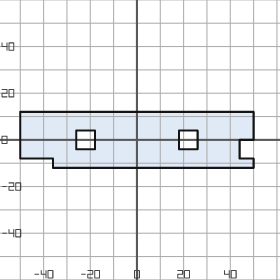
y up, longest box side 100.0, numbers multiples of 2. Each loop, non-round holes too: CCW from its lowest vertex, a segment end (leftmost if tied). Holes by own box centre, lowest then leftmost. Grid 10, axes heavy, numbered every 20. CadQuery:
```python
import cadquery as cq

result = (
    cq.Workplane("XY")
    .moveTo(-36.0, -12.0)
    .lineTo(50.0, -12.0)
    .lineTo(50.0, -8.0)
    .lineTo(44.0, -8.0)
    .lineTo(44.0, 0.0)
    .lineTo(50.0, 0.0)
    .lineTo(50.0, 12.0)
    .lineTo(-50.0, 12.0)
    .lineTo(-50.0, -8.0)
    .lineTo(-36.0, -8.0)
    .close()
    .moveTo(-26.0, -4.0)
    .lineTo(-18.0, -4.0)
    .lineTo(-18.0, 4.0)
    .lineTo(-26.0, 4.0)
    .close()
    .moveTo(18.0, -4.0)
    .lineTo(26.0, -4.0)
    .lineTo(26.0, 4.0)
    .lineTo(18.0, 4.0)
    .close()
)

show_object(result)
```